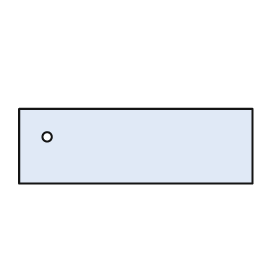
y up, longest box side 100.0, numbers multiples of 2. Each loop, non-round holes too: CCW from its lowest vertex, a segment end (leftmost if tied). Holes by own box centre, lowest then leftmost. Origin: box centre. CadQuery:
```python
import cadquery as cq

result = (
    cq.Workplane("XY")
    .moveTo(-50.0, -16.0)
    .lineTo(50.0, -16.0)
    .lineTo(50.0, 16.0)
    .lineTo(-50.0, 16.0)
    .close()
    .moveTo(-38.0, 4.0)
    .circle(2.0)
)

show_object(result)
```